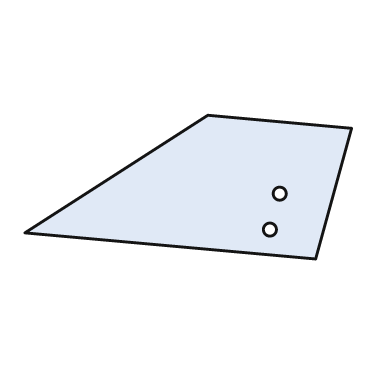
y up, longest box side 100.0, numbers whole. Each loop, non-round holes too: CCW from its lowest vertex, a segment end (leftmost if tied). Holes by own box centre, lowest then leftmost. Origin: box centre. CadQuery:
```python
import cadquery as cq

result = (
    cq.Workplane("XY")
    .moveTo(39.0, -22.0)
    .lineTo(50.0, 18.0)
    .lineTo(6.0, 22.0)
    .lineTo(-50.0, -14.0)
    .close()
    .moveTo(25.0, -13.0)
    .circle(2.0)
    .moveTo(28.0, -2.0)
    .circle(2.0)
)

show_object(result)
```